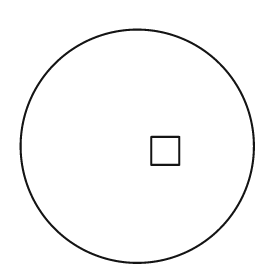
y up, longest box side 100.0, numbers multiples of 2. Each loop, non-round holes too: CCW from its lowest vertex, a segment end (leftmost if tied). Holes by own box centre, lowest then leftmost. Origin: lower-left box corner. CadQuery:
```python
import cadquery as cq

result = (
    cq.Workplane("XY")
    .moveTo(50.0, 50.0)
    .circle(50.0)
    .moveTo(56.0, 42.0)
    .lineTo(68.0, 42.0)
    .lineTo(68.0, 54.0)
    .lineTo(56.0, 54.0)
    .close()
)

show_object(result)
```